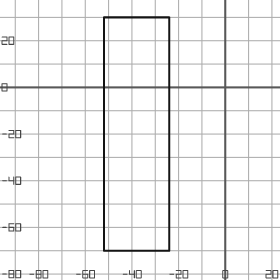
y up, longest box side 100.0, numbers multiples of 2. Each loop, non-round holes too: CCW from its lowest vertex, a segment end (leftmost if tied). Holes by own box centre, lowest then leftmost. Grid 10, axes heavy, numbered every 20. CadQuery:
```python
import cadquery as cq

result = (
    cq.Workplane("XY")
    .moveTo(-52.0, -70.0)
    .lineTo(-24.0, -70.0)
    .lineTo(-24.0, 30.0)
    .lineTo(-52.0, 30.0)
    .close()
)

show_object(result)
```